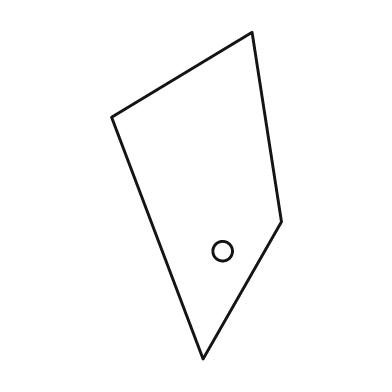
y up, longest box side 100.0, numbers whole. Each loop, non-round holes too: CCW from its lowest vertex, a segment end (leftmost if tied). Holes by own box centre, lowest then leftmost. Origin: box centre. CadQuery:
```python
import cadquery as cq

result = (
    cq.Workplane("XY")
    .moveTo(2.0, -50.0)
    .lineTo(26.0, -8.0)
    .lineTo(17.0, 50.0)
    .lineTo(-26.0, 24.0)
    .close()
    .moveTo(8.0, -17.0)
    .circle(3.0)
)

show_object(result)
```